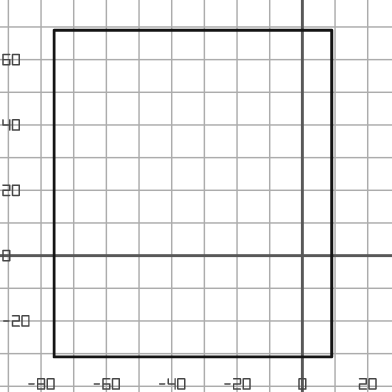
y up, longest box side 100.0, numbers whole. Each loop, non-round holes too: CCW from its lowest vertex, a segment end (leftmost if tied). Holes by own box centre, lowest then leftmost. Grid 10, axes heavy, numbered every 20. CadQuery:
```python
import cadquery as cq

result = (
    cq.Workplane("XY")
    .moveTo(-76.0, -31.0)
    .lineTo(9.0, -31.0)
    .lineTo(9.0, 69.0)
    .lineTo(-76.0, 69.0)
    .close()
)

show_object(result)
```